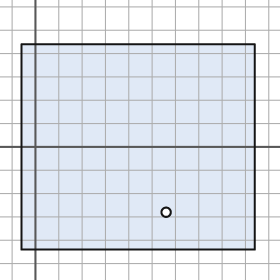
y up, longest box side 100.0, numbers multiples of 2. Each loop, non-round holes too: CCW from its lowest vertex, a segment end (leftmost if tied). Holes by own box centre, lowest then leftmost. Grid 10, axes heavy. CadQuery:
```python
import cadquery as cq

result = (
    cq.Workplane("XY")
    .moveTo(-6.0, -44.0)
    .lineTo(94.0, -44.0)
    .lineTo(94.0, 44.0)
    .lineTo(-6.0, 44.0)
    .close()
    .moveTo(56.0, -28.0)
    .circle(2.0)
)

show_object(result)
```